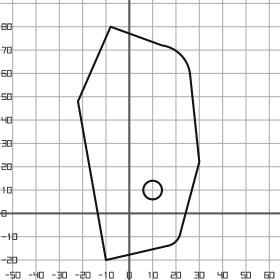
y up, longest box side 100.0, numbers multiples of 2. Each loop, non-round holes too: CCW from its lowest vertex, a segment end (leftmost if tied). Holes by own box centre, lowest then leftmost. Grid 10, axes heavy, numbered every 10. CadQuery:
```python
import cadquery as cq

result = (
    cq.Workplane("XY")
    .moveTo(-10.0, -20.0)
    .lineTo(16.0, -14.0)
    .threePointArc((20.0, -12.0), (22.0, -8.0))
    .lineTo(30.0, 22.0)
    .lineTo(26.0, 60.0)
    .threePointArc((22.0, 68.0), (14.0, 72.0))
    .lineTo(-8.0, 80.0)
    .lineTo(-22.0, 48.0)
    .close()
    .moveTo(10.0, 10.0)
    .circle(4.0)
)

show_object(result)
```